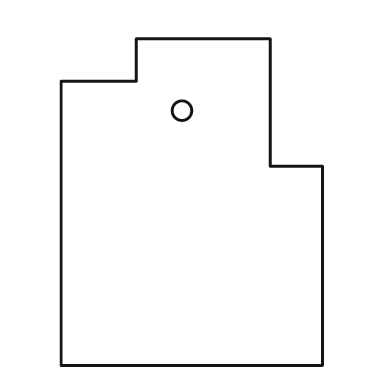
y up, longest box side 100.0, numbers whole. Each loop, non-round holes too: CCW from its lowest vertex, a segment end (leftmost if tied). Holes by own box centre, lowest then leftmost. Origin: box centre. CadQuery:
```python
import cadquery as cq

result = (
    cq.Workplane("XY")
    .moveTo(-40.0, -50.0)
    .lineTo(40.0, -50.0)
    .lineTo(40.0, 11.0)
    .lineTo(24.0, 11.0)
    .lineTo(24.0, 50.0)
    .lineTo(-17.0, 50.0)
    .lineTo(-17.0, 37.0)
    .lineTo(-40.0, 37.0)
    .close()
    .moveTo(-3.0, 28.0)
    .circle(3.0)
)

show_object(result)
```